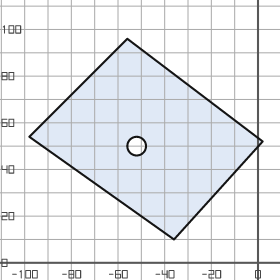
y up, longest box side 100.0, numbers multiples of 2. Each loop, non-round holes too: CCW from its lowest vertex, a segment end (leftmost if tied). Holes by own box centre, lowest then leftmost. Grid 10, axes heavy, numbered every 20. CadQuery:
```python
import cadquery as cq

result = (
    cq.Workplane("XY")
    .moveTo(-36.0, 10.0)
    .lineTo(2.0, 52.0)
    .lineTo(-56.0, 96.0)
    .lineTo(-98.0, 54.0)
    .close()
    .moveTo(-52.0, 50.0)
    .circle(4.0)
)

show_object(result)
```